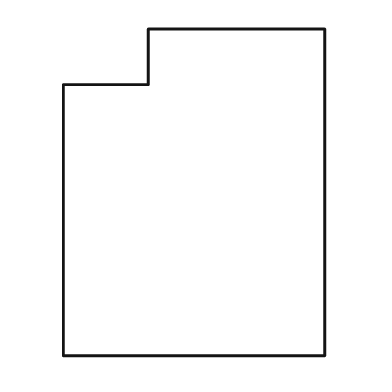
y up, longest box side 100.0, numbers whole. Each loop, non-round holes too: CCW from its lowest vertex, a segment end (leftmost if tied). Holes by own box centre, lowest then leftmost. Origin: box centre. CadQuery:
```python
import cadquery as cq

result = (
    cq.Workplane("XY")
    .moveTo(-40.0, -50.0)
    .lineTo(40.0, -50.0)
    .lineTo(40.0, 50.0)
    .lineTo(-14.0, 50.0)
    .lineTo(-14.0, 33.0)
    .lineTo(-40.0, 33.0)
    .close()
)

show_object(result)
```